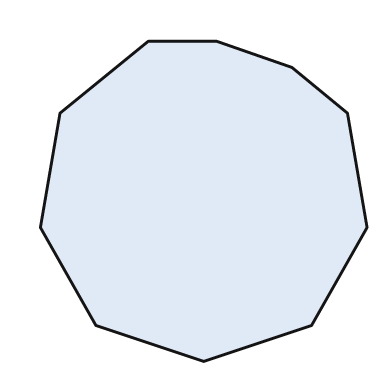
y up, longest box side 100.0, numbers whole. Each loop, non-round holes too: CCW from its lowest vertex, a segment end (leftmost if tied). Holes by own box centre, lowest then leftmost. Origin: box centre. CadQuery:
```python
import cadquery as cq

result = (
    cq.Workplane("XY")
    .moveTo(0.0, -49.0)
    .lineTo(33.0, -38.0)
    .lineTo(50.0, -8.0)
    .lineTo(44.0, 27.0)
    .lineTo(27.0, 41.0)
    .lineTo(4.0, 49.0)
    .lineTo(-17.0, 49.0)
    .lineTo(-44.0, 27.0)
    .lineTo(-50.0, -8.0)
    .lineTo(-33.0, -38.0)
    .close()
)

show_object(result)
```